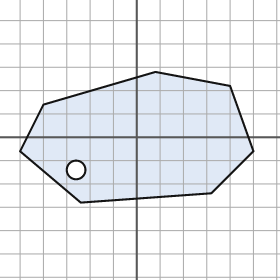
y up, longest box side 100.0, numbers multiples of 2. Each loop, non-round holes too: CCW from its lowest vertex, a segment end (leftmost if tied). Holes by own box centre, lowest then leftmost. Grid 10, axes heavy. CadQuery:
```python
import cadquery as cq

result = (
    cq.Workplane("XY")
    .moveTo(-24.0, -28.0)
    .lineTo(32.0, -24.0)
    .lineTo(50.0, -6.0)
    .lineTo(40.0, 22.0)
    .lineTo(8.0, 28.0)
    .lineTo(-40.0, 14.0)
    .lineTo(-50.0, -6.0)
    .close()
    .moveTo(-26.0, -14.0)
    .circle(4.0)
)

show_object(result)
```